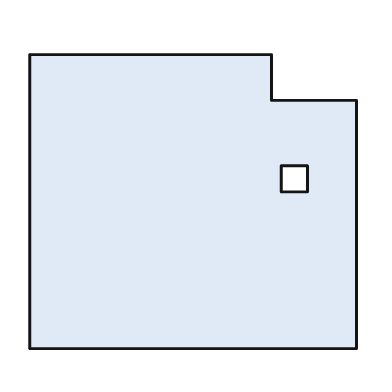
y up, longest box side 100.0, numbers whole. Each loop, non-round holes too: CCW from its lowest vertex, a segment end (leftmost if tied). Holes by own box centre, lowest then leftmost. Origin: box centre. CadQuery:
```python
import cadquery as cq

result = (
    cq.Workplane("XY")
    .moveTo(-50.0, -45.0)
    .lineTo(50.0, -45.0)
    .lineTo(50.0, 31.0)
    .lineTo(24.0, 31.0)
    .lineTo(24.0, 45.0)
    .lineTo(-50.0, 45.0)
    .close()
    .moveTo(27.0, 3.0)
    .lineTo(35.0, 3.0)
    .lineTo(35.0, 11.0)
    .lineTo(27.0, 11.0)
    .close()
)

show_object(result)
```